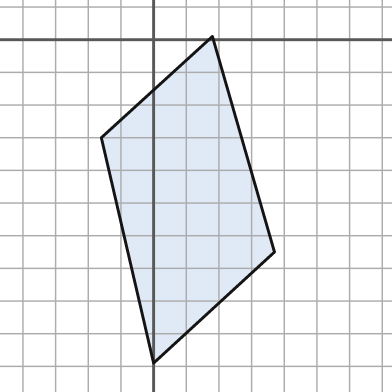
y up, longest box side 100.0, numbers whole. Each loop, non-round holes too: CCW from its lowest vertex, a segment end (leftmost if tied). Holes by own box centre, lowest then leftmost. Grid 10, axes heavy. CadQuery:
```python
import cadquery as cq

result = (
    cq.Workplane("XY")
    .moveTo(0.0, -99.0)
    .lineTo(37.0, -65.0)
    .lineTo(18.0, 1.0)
    .lineTo(-16.0, -30.0)
    .close()
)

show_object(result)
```